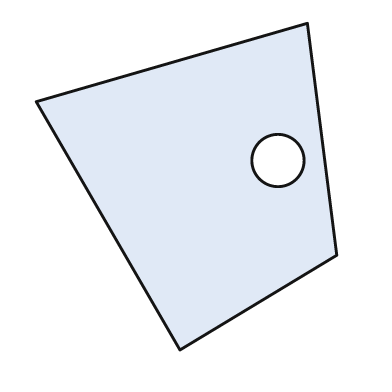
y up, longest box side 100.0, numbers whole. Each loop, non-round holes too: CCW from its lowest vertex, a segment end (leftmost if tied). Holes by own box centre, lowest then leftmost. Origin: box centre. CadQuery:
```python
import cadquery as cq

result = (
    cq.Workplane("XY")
    .moveTo(-2.0, -50.0)
    .lineTo(46.0, -21.0)
    .lineTo(37.0, 50.0)
    .lineTo(-46.0, 26.0)
    .close()
    .moveTo(28.0, 8.0)
    .circle(8.0)
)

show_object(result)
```